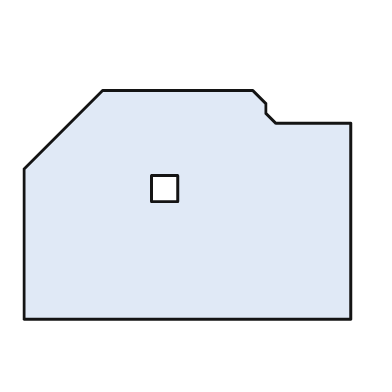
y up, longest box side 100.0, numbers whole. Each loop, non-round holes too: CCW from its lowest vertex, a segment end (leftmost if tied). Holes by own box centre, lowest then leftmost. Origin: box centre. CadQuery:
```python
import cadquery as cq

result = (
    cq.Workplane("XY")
    .moveTo(-50.0, -35.0)
    .lineTo(50.0, -35.0)
    .lineTo(50.0, 25.0)
    .lineTo(27.0, 25.0)
    .lineTo(24.0, 28.0)
    .lineTo(24.0, 31.0)
    .lineTo(20.0, 35.0)
    .lineTo(-26.0, 35.0)
    .lineTo(-50.0, 11.0)
    .close()
    .moveTo(-11.0, 1.0)
    .lineTo(-3.0, 1.0)
    .lineTo(-3.0, 9.0)
    .lineTo(-11.0, 9.0)
    .close()
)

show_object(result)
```